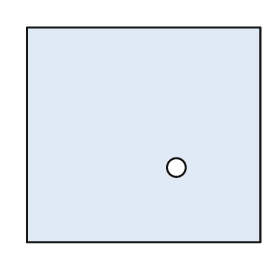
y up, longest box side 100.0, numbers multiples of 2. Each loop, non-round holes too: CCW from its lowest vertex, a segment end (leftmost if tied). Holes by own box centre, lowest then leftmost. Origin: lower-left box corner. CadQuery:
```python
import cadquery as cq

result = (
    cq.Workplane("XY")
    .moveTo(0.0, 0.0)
    .lineTo(100.0, 0.0)
    .lineTo(100.0, 92.0)
    .lineTo(0.0, 92.0)
    .close()
    .moveTo(64.0, 32.0)
    .circle(4.0)
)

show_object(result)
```